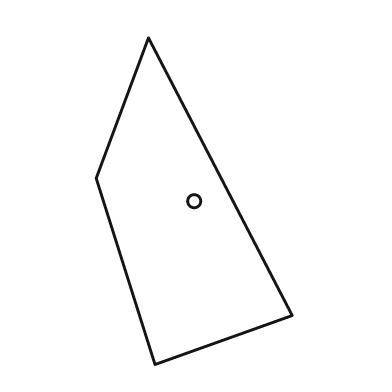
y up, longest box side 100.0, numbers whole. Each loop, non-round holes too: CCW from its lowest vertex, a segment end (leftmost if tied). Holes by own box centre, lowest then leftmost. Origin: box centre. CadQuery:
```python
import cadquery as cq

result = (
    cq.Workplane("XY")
    .moveTo(-12.0, -50.0)
    .lineTo(30.0, -35.0)
    .lineTo(-14.0, 50.0)
    .lineTo(-30.0, 7.0)
    .close()
    .moveTo(0.0, 0.0)
    .circle(2.0)
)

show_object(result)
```